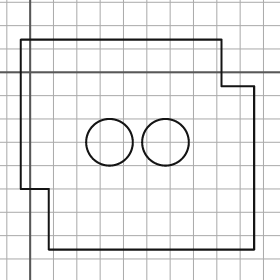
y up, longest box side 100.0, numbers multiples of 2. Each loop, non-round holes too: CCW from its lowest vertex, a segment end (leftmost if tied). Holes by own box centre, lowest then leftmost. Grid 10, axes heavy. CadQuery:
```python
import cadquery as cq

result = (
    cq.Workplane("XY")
    .moveTo(8.0, -76.0)
    .lineTo(96.0, -76.0)
    .lineTo(96.0, -6.0)
    .lineTo(82.0, -6.0)
    .lineTo(82.0, 14.0)
    .lineTo(-4.0, 14.0)
    .lineTo(-4.0, -50.0)
    .lineTo(8.0, -50.0)
    .close()
    .moveTo(34.0, -30.0)
    .circle(10.0)
    .moveTo(58.0, -30.0)
    .circle(10.0)
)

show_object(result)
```